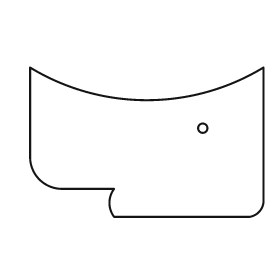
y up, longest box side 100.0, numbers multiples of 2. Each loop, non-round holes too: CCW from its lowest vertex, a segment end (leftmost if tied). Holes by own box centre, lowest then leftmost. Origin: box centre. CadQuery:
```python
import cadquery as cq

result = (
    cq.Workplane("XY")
    .moveTo(-14.0, -32.0)
    .lineTo(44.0, -32.0)
    .threePointArc((48.0, -30.0), (50.0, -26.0))
    .lineTo(50.0, 32.0)
    .threePointArc((0.0, 18.0), (-50.0, 32.0))
    .lineTo(-50.0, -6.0)
    .threePointArc((-46.0, -16.0), (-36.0, -20.0))
    .lineTo(-14.0, -20.0)
    .threePointArc((-16.0, -26.0), (-14.0, -32.0))
    .close()
    .moveTo(24.0, 6.0)
    .circle(2.0)
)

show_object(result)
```